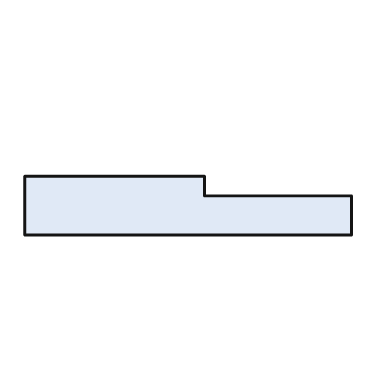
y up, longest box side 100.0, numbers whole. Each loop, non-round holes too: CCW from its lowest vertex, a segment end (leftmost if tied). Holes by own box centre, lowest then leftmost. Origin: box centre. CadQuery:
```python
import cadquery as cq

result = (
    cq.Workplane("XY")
    .moveTo(-50.0, -9.0)
    .lineTo(50.0, -9.0)
    .lineTo(50.0, 3.0)
    .lineTo(5.0, 3.0)
    .lineTo(5.0, 9.0)
    .lineTo(-50.0, 9.0)
    .close()
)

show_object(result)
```